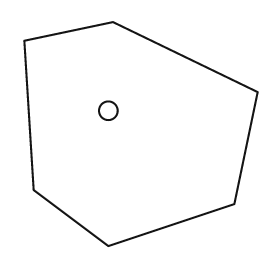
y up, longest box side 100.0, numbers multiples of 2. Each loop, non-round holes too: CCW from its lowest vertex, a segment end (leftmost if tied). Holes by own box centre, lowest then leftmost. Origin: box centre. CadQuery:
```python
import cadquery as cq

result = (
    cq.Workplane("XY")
    .moveTo(-14.0, -48.0)
    .lineTo(40.0, -30.0)
    .lineTo(50.0, 18.0)
    .lineTo(-12.0, 48.0)
    .lineTo(-50.0, 40.0)
    .lineTo(-46.0, -24.0)
    .close()
    .moveTo(-14.0, 10.0)
    .circle(4.0)
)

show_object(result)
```